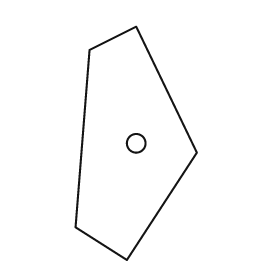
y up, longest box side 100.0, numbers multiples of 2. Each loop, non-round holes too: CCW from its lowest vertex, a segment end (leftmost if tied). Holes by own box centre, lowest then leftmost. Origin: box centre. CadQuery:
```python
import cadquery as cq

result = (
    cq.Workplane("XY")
    .moveTo(-4.0, -50.0)
    .lineTo(26.0, -4.0)
    .lineTo(0.0, 50.0)
    .lineTo(-20.0, 40.0)
    .lineTo(-26.0, -36.0)
    .close()
    .moveTo(0.0, 0.0)
    .circle(4.0)
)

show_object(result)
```